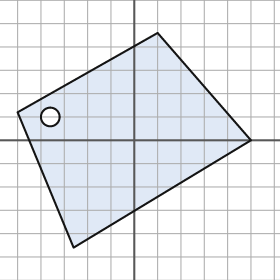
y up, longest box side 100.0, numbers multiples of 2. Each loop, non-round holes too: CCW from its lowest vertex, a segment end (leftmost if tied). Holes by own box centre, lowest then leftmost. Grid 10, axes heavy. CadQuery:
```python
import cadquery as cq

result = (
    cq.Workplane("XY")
    .moveTo(-26.0, -46.0)
    .lineTo(50.0, 0.0)
    .lineTo(10.0, 46.0)
    .lineTo(-50.0, 12.0)
    .close()
    .moveTo(-36.0, 10.0)
    .circle(4.0)
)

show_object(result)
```